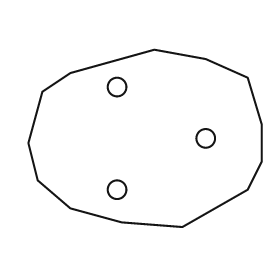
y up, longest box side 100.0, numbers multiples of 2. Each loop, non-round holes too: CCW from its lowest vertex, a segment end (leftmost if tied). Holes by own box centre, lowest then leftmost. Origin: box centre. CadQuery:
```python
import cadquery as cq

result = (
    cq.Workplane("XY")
    .moveTo(16.0, -38.0)
    .lineTo(44.0, -22.0)
    .lineTo(50.0, -10.0)
    .lineTo(50.0, 6.0)
    .lineTo(44.0, 26.0)
    .lineTo(26.0, 34.0)
    .lineTo(4.0, 38.0)
    .lineTo(-32.0, 28.0)
    .lineTo(-44.0, 20.0)
    .lineTo(-50.0, -2.0)
    .lineTo(-46.0, -18.0)
    .lineTo(-32.0, -30.0)
    .lineTo(-10.0, -36.0)
    .close()
    .moveTo(-12.0, -22.0)
    .circle(4.0)
    .moveTo(26.0, 0.0)
    .circle(4.0)
    .moveTo(-12.0, 22.0)
    .circle(4.0)
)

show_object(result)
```